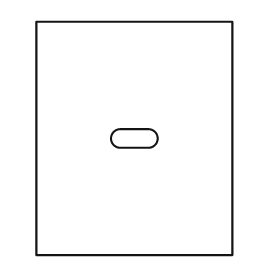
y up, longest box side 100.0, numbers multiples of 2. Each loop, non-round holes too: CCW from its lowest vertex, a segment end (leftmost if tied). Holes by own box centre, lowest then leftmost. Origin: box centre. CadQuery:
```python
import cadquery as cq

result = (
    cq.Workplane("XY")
    .moveTo(-42.0, -50.0)
    .lineTo(42.0, -50.0)
    .lineTo(42.0, 50.0)
    .lineTo(-42.0, 50.0)
    .close()
    .moveTo(-6.0, -4.0)
    .lineTo(6.0, -4.0)
    .threePointArc((10.0, 0.0), (6.0, 4.0))
    .lineTo(-6.0, 4.0)
    .threePointArc((-10.0, 0.0), (-6.0, -4.0))
    .close()
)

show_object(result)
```